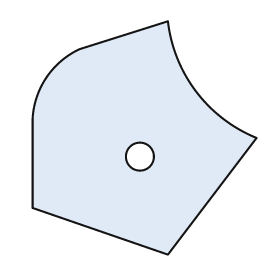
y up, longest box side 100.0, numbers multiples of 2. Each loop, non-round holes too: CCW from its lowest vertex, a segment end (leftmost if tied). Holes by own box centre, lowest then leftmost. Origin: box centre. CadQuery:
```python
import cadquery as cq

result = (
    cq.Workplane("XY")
    .moveTo(10.0, -50.0)
    .lineTo(48.0, 0.0)
    .threePointArc((22.0, 20.0), (10.0, 50.0))
    .lineTo(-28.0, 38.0)
    .threePointArc((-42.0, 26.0), (-48.0, 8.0))
    .lineTo(-48.0, -30.0)
    .close()
    .moveTo(-2.0, -8.0)
    .circle(6.0)
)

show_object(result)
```